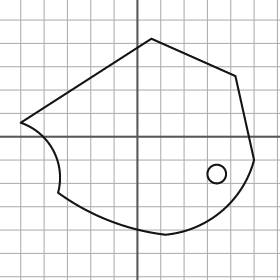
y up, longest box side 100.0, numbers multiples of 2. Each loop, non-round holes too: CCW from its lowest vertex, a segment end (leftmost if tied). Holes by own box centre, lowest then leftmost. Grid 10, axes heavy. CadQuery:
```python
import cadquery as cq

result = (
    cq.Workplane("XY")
    .moveTo(12.0, -42.0)
    .threePointArc((36.0, -32.0), (50.0, -10.0))
    .lineTo(42.0, 26.0)
    .lineTo(6.0, 42.0)
    .lineTo(-50.0, 6.0)
    .threePointArc((-36.0, -6.0), (-34.0, -24.0))
    .threePointArc((-12.0, -36.0), (12.0, -42.0))
    .close()
    .moveTo(34.0, -16.0)
    .circle(4.0)
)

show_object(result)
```